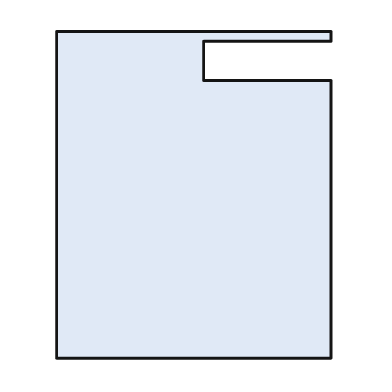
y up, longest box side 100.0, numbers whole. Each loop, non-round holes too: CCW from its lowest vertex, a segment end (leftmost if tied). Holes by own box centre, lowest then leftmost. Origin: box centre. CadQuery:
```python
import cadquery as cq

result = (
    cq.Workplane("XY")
    .moveTo(-42.0, -50.0)
    .lineTo(42.0, -50.0)
    .lineTo(42.0, 35.0)
    .lineTo(3.0, 35.0)
    .lineTo(3.0, 47.0)
    .lineTo(42.0, 47.0)
    .lineTo(42.0, 50.0)
    .lineTo(-42.0, 50.0)
    .close()
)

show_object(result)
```